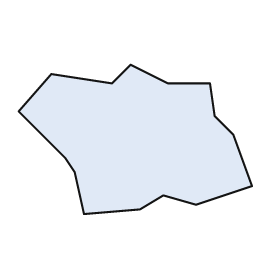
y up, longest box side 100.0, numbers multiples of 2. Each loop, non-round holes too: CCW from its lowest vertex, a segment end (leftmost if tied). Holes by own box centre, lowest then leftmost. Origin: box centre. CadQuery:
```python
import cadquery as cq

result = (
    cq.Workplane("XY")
    .moveTo(-22.0, -32.0)
    .lineTo(2.0, -30.0)
    .lineTo(12.0, -24.0)
    .lineTo(26.0, -28.0)
    .lineTo(50.0, -20.0)
    .lineTo(42.0, 2.0)
    .lineTo(34.0, 10.0)
    .lineTo(32.0, 24.0)
    .lineTo(14.0, 24.0)
    .lineTo(-2.0, 32.0)
    .lineTo(-10.0, 24.0)
    .lineTo(-36.0, 28.0)
    .lineTo(-50.0, 12.0)
    .lineTo(-30.0, -8.0)
    .lineTo(-26.0, -14.0)
    .close()
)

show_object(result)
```